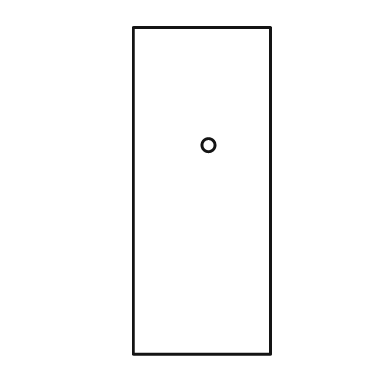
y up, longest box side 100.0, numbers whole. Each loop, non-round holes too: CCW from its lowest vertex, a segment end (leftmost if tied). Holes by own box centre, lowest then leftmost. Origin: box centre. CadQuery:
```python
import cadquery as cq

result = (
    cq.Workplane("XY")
    .moveTo(-21.0, -50.0)
    .lineTo(21.0, -50.0)
    .lineTo(21.0, 50.0)
    .lineTo(-21.0, 50.0)
    .close()
    .moveTo(2.0, 14.0)
    .circle(2.0)
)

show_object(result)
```